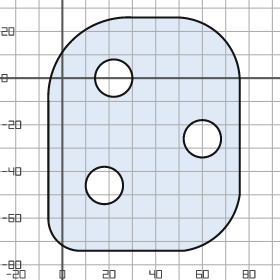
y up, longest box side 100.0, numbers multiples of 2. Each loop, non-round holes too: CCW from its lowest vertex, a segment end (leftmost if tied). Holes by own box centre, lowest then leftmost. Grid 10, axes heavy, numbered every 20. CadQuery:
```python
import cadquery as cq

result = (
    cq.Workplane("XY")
    .moveTo(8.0, -74.0)
    .lineTo(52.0, -74.0)
    .threePointArc((68.0, -66.0), (76.0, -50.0))
    .lineTo(76.0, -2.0)
    .threePointArc((68.0, 18.0), (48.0, 26.0))
    .lineTo(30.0, 26.0)
    .threePointArc((4.0, 16.0), (-6.0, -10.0))
    .lineTo(-6.0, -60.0)
    .threePointArc((-2.0, -70.0), (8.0, -74.0))
    .close()
    .moveTo(18.0, -46.0)
    .circle(8.0)
    .moveTo(60.0, -26.0)
    .circle(8.0)
    .moveTo(22.0, 0.0)
    .circle(8.0)
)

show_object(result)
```